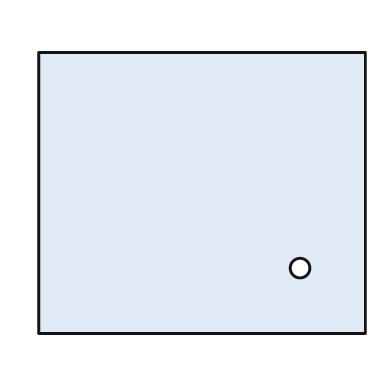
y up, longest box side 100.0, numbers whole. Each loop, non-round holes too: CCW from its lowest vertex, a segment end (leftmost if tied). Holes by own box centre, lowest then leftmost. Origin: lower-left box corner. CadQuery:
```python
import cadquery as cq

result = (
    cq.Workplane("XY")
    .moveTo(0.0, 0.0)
    .lineTo(100.0, 0.0)
    .lineTo(100.0, 86.0)
    .lineTo(0.0, 86.0)
    .close()
    .moveTo(80.0, 20.0)
    .circle(3.0)
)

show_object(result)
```